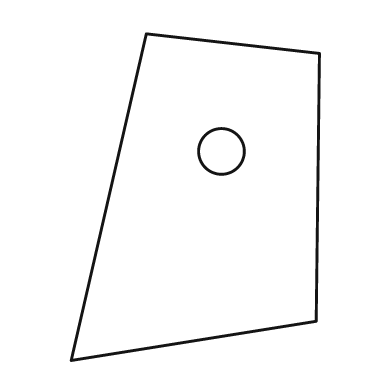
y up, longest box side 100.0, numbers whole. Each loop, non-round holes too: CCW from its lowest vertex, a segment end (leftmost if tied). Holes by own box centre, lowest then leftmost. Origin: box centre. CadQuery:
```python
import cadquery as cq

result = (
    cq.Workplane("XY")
    .moveTo(-38.0, -50.0)
    .lineTo(37.0, -38.0)
    .lineTo(38.0, 44.0)
    .lineTo(-15.0, 50.0)
    .close()
    .moveTo(8.0, 14.0)
    .circle(7.0)
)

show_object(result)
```